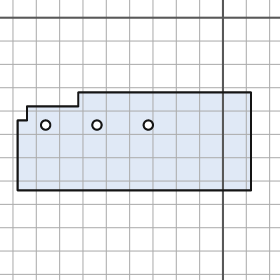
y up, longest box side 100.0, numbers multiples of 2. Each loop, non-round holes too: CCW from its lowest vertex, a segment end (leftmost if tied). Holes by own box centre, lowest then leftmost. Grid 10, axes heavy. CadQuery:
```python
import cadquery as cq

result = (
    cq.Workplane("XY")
    .moveTo(-88.0, -74.0)
    .lineTo(12.0, -74.0)
    .lineTo(12.0, -32.0)
    .lineTo(-62.0, -32.0)
    .lineTo(-62.0, -38.0)
    .lineTo(-84.0, -38.0)
    .lineTo(-84.0, -44.0)
    .lineTo(-88.0, -44.0)
    .close()
    .moveTo(-76.0, -46.0)
    .circle(2.0)
    .moveTo(-54.0, -46.0)
    .circle(2.0)
    .moveTo(-32.0, -46.0)
    .circle(2.0)
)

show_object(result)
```